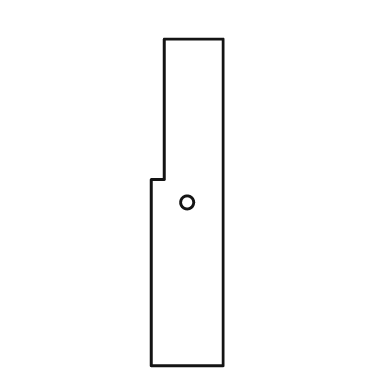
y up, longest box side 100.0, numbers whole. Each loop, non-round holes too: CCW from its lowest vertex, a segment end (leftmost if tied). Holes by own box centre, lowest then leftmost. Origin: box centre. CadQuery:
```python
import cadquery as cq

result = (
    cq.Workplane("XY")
    .moveTo(-11.0, -50.0)
    .lineTo(11.0, -50.0)
    .lineTo(11.0, 50.0)
    .lineTo(-7.0, 50.0)
    .lineTo(-7.0, 7.0)
    .lineTo(-11.0, 7.0)
    .close()
    .moveTo(0.0, 0.0)
    .circle(2.0)
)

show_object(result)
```